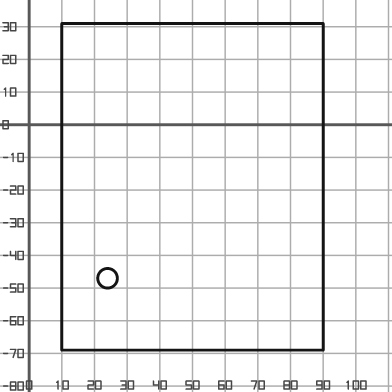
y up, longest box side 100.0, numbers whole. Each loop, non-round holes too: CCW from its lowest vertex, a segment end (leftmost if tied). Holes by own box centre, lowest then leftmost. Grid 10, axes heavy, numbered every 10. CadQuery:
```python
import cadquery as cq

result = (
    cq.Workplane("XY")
    .moveTo(10.0, -69.0)
    .lineTo(90.0, -69.0)
    .lineTo(90.0, 31.0)
    .lineTo(10.0, 31.0)
    .close()
    .moveTo(24.0, -47.0)
    .circle(3.0)
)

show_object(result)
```